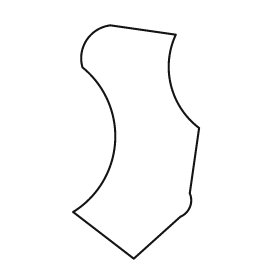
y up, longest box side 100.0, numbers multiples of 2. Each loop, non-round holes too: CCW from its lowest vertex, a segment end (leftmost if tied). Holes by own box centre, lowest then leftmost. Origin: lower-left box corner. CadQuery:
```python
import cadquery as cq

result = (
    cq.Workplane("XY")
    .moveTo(26.0, 0.0)
    .lineTo(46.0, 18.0)
    .threePointArc((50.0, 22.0), (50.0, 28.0))
    .lineTo(54.0, 56.0)
    .threePointArc((42.0, 74.0), (44.0, 96.0))
    .lineTo(16.0, 100.0)
    .threePointArc((6.0, 94.0), (4.0, 82.0))
    .threePointArc((18.0, 50.0), (0.0, 20.0))
    .close()
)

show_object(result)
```